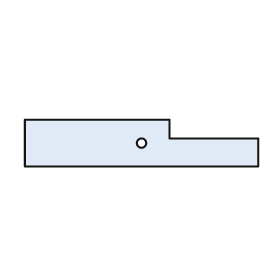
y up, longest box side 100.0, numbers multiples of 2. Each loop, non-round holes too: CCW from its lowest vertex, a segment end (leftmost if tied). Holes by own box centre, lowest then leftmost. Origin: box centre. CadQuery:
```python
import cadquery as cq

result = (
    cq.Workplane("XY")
    .moveTo(-50.0, -10.0)
    .lineTo(50.0, -10.0)
    .lineTo(50.0, 2.0)
    .lineTo(12.0, 2.0)
    .lineTo(12.0, 10.0)
    .lineTo(-50.0, 10.0)
    .close()
    .moveTo(0.0, 0.0)
    .circle(2.0)
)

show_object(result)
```